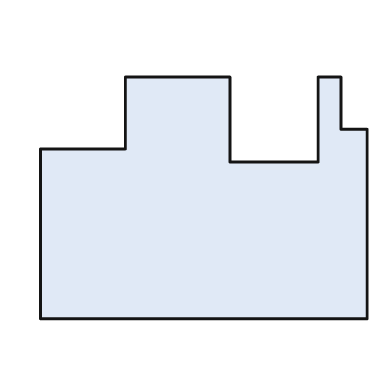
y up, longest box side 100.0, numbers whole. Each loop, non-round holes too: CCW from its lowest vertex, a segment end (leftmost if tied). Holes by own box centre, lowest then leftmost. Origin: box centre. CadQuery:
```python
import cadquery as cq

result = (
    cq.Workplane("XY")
    .moveTo(-50.0, -37.0)
    .lineTo(50.0, -37.0)
    .lineTo(50.0, 21.0)
    .lineTo(42.0, 21.0)
    .lineTo(42.0, 37.0)
    .lineTo(35.0, 37.0)
    .lineTo(35.0, 11.0)
    .lineTo(8.0, 11.0)
    .lineTo(8.0, 37.0)
    .lineTo(-24.0, 37.0)
    .lineTo(-24.0, 15.0)
    .lineTo(-50.0, 15.0)
    .close()
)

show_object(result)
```